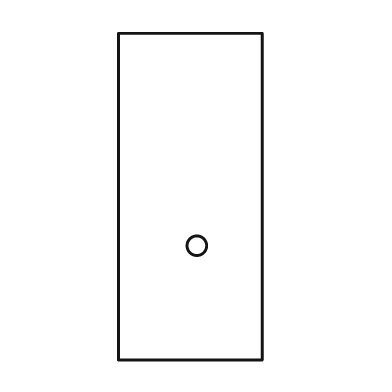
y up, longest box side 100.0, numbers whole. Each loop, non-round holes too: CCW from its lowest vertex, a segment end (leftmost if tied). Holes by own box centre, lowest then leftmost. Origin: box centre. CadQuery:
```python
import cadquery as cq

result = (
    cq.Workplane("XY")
    .moveTo(-22.0, -50.0)
    .lineTo(22.0, -50.0)
    .lineTo(22.0, 50.0)
    .lineTo(-22.0, 50.0)
    .close()
    .moveTo(2.0, -15.0)
    .circle(3.0)
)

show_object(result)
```